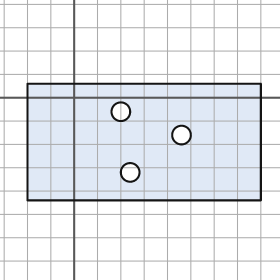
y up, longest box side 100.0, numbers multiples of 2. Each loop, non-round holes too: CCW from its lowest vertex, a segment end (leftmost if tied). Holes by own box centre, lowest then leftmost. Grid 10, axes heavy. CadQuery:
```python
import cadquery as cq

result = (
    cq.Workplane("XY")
    .moveTo(-20.0, -44.0)
    .lineTo(80.0, -44.0)
    .lineTo(80.0, 6.0)
    .lineTo(-20.0, 6.0)
    .close()
    .moveTo(24.0, -32.0)
    .circle(4.0)
    .moveTo(46.0, -16.0)
    .circle(4.0)
    .moveTo(20.0, -6.0)
    .circle(4.0)
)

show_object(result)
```